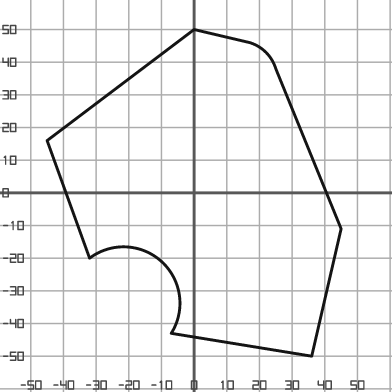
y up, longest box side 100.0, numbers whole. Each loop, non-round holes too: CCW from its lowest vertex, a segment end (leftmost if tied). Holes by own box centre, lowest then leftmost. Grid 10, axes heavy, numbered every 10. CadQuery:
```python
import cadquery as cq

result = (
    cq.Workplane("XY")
    .moveTo(36.0, -50.0)
    .lineTo(45.0, -11.0)
    .lineTo(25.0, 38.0)
    .threePointArc((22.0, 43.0), (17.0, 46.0))
    .lineTo(0.0, 50.0)
    .lineTo(-45.0, 16.0)
    .lineTo(-32.0, -20.0)
    .threePointArc((-10.0, -21.0), (-7.0, -43.0))
    .close()
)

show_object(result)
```